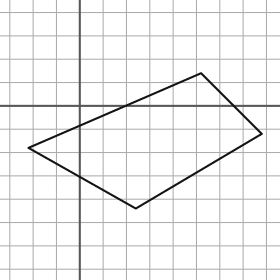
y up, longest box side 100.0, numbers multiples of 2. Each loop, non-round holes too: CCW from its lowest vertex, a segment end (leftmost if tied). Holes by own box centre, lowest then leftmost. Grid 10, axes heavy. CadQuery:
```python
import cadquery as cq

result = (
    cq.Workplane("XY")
    .moveTo(24.0, -44.0)
    .lineTo(78.0, -12.0)
    .lineTo(52.0, 14.0)
    .lineTo(-22.0, -18.0)
    .close()
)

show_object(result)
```